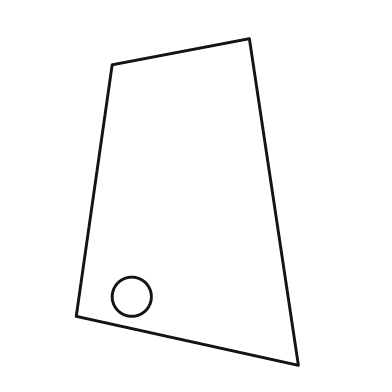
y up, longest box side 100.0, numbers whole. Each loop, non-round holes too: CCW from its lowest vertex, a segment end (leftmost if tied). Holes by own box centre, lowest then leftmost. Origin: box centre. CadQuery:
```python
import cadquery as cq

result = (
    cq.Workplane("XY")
    .moveTo(34.0, -50.0)
    .lineTo(19.0, 50.0)
    .lineTo(-23.0, 42.0)
    .lineTo(-34.0, -35.0)
    .close()
    .moveTo(-17.0, -29.0)
    .circle(6.0)
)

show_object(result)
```